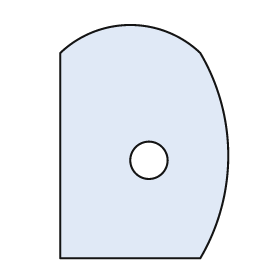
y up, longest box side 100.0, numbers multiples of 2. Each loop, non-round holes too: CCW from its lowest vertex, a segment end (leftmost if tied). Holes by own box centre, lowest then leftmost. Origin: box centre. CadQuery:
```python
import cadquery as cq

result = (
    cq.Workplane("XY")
    .moveTo(-36.0, -50.0)
    .lineTo(24.0, -50.0)
    .threePointArc((36.0, -6.0), (24.0, 38.0))
    .threePointArc((-6.0, 50.0), (-36.0, 38.0))
    .close()
    .moveTo(2.0, -8.0)
    .circle(8.0)
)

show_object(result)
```